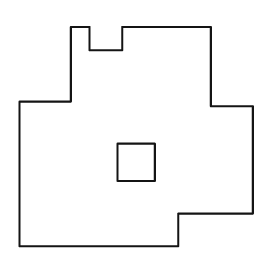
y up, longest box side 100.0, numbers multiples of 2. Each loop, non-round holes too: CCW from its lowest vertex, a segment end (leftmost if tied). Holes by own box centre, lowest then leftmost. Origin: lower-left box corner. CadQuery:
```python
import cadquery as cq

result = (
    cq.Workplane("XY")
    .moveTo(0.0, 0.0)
    .lineTo(68.0, 0.0)
    .lineTo(68.0, 14.0)
    .lineTo(100.0, 14.0)
    .lineTo(100.0, 60.0)
    .lineTo(82.0, 60.0)
    .lineTo(82.0, 94.0)
    .lineTo(44.0, 94.0)
    .lineTo(44.0, 84.0)
    .lineTo(30.0, 84.0)
    .lineTo(30.0, 94.0)
    .lineTo(22.0, 94.0)
    .lineTo(22.0, 62.0)
    .lineTo(0.0, 62.0)
    .close()
    .moveTo(42.0, 28.0)
    .lineTo(58.0, 28.0)
    .lineTo(58.0, 44.0)
    .lineTo(42.0, 44.0)
    .close()
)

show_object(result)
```